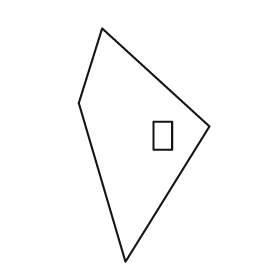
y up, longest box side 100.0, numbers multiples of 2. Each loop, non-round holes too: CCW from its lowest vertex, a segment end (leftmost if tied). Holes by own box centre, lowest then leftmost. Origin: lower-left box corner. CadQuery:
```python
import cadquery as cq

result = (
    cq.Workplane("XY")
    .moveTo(20.0, 0.0)
    .lineTo(56.0, 58.0)
    .lineTo(10.0, 100.0)
    .lineTo(0.0, 68.0)
    .close()
    .moveTo(32.0, 48.0)
    .lineTo(40.0, 48.0)
    .lineTo(40.0, 60.0)
    .lineTo(32.0, 60.0)
    .close()
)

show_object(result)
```